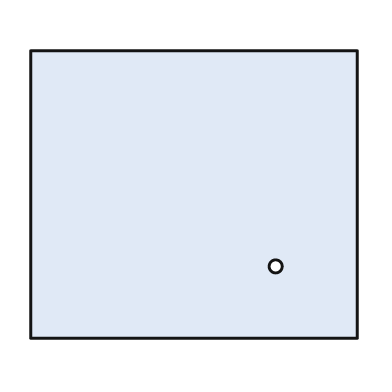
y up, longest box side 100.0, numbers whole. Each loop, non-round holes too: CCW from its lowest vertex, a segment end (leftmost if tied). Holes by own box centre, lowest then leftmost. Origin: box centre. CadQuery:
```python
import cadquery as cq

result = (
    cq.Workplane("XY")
    .moveTo(-50.0, -44.0)
    .lineTo(50.0, -44.0)
    .lineTo(50.0, 44.0)
    .lineTo(-50.0, 44.0)
    .close()
    .moveTo(25.0, -22.0)
    .circle(2.0)
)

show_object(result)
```